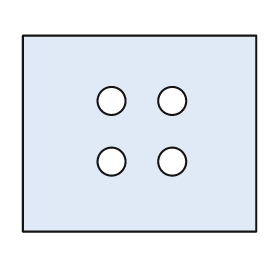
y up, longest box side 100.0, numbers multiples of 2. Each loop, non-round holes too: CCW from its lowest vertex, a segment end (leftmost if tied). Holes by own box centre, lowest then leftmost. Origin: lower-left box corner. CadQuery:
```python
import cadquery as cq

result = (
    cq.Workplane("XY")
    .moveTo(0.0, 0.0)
    .lineTo(100.0, 0.0)
    .lineTo(100.0, 84.0)
    .lineTo(0.0, 84.0)
    .close()
    .moveTo(38.0, 30.0)
    .circle(6.0)
    .moveTo(64.0, 30.0)
    .circle(6.0)
    .moveTo(38.0, 56.0)
    .circle(6.0)
    .moveTo(64.0, 56.0)
    .circle(6.0)
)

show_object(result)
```